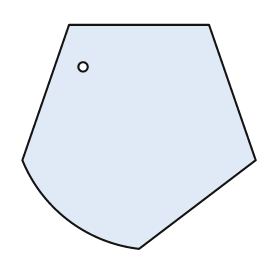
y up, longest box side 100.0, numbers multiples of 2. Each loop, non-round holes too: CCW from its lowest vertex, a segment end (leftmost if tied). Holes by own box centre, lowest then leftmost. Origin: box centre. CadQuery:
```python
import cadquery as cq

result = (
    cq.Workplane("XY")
    .moveTo(0.0, -48.0)
    .lineTo(50.0, -10.0)
    .lineTo(30.0, 48.0)
    .lineTo(-30.0, 48.0)
    .lineTo(-50.0, -10.0)
    .threePointArc((-30.0, -36.0), (0.0, -48.0))
    .close()
    .moveTo(-24.0, 30.0)
    .circle(2.0)
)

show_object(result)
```